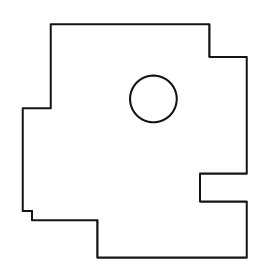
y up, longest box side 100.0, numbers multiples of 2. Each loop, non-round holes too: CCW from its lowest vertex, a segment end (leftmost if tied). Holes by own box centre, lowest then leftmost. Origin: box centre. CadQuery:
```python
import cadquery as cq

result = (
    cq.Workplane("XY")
    .moveTo(-16.0, -50.0)
    .lineTo(48.0, -50.0)
    .lineTo(48.0, -26.0)
    .lineTo(28.0, -26.0)
    .lineTo(28.0, -14.0)
    .lineTo(48.0, -14.0)
    .lineTo(48.0, 36.0)
    .lineTo(32.0, 36.0)
    .lineTo(32.0, 50.0)
    .lineTo(-36.0, 50.0)
    .lineTo(-36.0, 14.0)
    .lineTo(-48.0, 14.0)
    .lineTo(-48.0, -30.0)
    .lineTo(-44.0, -30.0)
    .lineTo(-44.0, -34.0)
    .lineTo(-16.0, -34.0)
    .close()
    .moveTo(8.0, 18.0)
    .circle(10.0)
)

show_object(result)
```